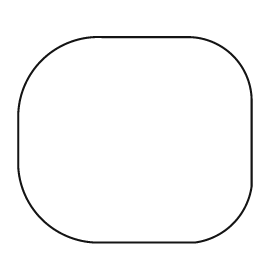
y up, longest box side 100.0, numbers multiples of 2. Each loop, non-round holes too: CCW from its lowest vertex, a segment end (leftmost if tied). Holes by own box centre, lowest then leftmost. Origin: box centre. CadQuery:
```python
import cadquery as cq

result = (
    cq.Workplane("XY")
    .moveTo(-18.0, -44.0)
    .lineTo(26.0, -44.0)
    .threePointArc((42.0, -36.0), (50.0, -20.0))
    .lineTo(50.0, 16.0)
    .threePointArc((42.0, 36.0), (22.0, 44.0))
    .lineTo(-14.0, 44.0)
    .threePointArc((-40.0, 34.0), (-50.0, 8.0))
    .lineTo(-50.0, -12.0)
    .threePointArc((-40.0, -34.0), (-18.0, -44.0))
    .close()
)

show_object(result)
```